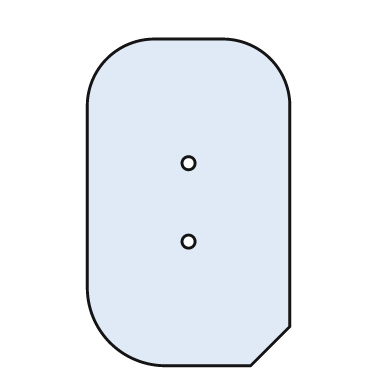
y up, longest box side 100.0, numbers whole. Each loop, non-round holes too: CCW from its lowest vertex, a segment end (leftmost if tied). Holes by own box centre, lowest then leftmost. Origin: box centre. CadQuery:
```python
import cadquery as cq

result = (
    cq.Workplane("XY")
    .moveTo(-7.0, -50.0)
    .lineTo(19.0, -50.0)
    .lineTo(31.0, -38.0)
    .lineTo(31.0, 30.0)
    .threePointArc((25.0, 44.0), (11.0, 50.0))
    .lineTo(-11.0, 50.0)
    .threePointArc((-25.0, 44.0), (-31.0, 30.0))
    .lineTo(-31.0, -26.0)
    .threePointArc((-24.0, -43.0), (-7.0, -50.0))
    .close()
    .moveTo(0.0, -12.0)
    .circle(2.0)
    .moveTo(0.0, 12.0)
    .circle(2.0)
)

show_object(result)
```